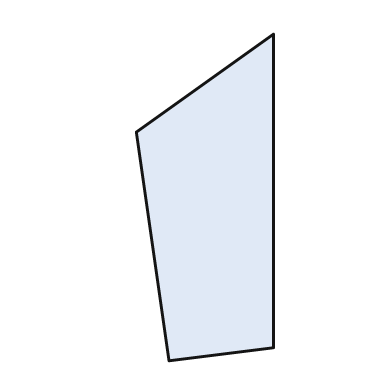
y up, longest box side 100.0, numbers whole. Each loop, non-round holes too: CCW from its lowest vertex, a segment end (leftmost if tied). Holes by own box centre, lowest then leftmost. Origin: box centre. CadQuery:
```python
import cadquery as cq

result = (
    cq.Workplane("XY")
    .moveTo(-11.0, -50.0)
    .lineTo(21.0, -46.0)
    .lineTo(21.0, 50.0)
    .lineTo(-21.0, 20.0)
    .close()
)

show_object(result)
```